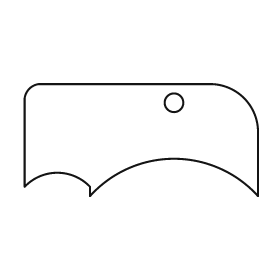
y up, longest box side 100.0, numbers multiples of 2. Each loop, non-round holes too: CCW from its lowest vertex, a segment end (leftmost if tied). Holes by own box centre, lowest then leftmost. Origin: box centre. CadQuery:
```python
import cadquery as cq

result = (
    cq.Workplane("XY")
    .moveTo(-22.0, -24.0)
    .threePointArc((14.0, -8.0), (50.0, -24.0))
    .lineTo(50.0, 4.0)
    .threePointArc((44.0, 18.0), (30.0, 24.0))
    .lineTo(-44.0, 24.0)
    .threePointArc((-48.0, 22.0), (-50.0, 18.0))
    .lineTo(-50.0, -20.0)
    .threePointArc((-36.0, -14.0), (-22.0, -20.0))
    .close()
    .moveTo(14.0, 16.0)
    .circle(4.0)
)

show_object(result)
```